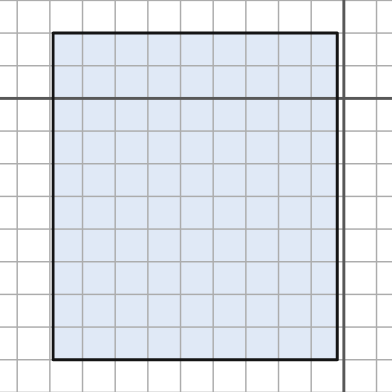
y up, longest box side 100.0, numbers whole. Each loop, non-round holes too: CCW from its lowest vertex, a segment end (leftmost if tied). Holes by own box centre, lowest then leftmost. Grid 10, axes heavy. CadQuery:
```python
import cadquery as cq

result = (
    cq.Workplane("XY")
    .moveTo(-89.0, -80.0)
    .lineTo(-2.0, -80.0)
    .lineTo(-2.0, 20.0)
    .lineTo(-89.0, 20.0)
    .close()
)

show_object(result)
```